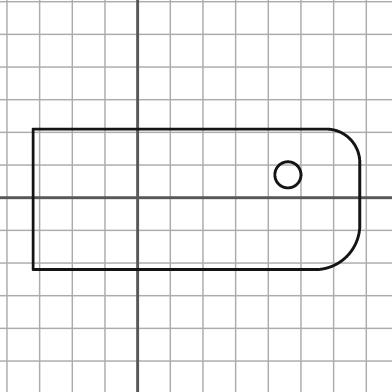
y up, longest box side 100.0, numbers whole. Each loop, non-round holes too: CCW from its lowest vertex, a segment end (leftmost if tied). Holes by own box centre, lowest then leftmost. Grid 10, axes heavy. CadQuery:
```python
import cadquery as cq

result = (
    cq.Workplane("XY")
    .moveTo(-32.0, -22.0)
    .lineTo(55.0, -22.0)
    .threePointArc((64.0, -18.0), (68.0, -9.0))
    .lineTo(68.0, 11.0)
    .threePointArc((65.0, 18.0), (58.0, 21.0))
    .lineTo(-32.0, 21.0)
    .close()
    .moveTo(46.0, 7.0)
    .circle(4.0)
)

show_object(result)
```